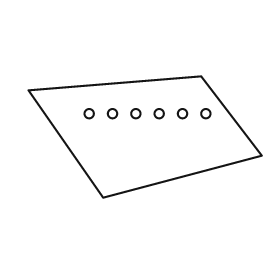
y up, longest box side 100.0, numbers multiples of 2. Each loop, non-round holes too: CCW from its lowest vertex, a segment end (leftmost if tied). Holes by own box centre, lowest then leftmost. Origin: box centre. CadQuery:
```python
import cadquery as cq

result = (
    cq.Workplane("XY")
    .moveTo(-18.0, -26.0)
    .lineTo(50.0, -8.0)
    .lineTo(24.0, 26.0)
    .lineTo(-50.0, 20.0)
    .close()
    .moveTo(-24.0, 10.0)
    .circle(2.0)
    .moveTo(-14.0, 10.0)
    .circle(2.0)
    .moveTo(-4.0, 10.0)
    .circle(2.0)
    .moveTo(6.0, 10.0)
    .circle(2.0)
    .moveTo(16.0, 10.0)
    .circle(2.0)
    .moveTo(26.0, 10.0)
    .circle(2.0)
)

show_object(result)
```